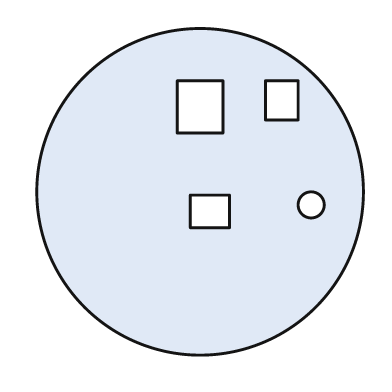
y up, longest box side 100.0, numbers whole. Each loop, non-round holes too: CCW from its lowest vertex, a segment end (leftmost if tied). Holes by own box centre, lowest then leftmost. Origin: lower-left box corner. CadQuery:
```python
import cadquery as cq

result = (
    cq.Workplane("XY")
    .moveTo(50.0, 50.0)
    .circle(50.0)
    .moveTo(47.0, 39.0)
    .lineTo(59.0, 39.0)
    .lineTo(59.0, 49.0)
    .lineTo(47.0, 49.0)
    .close()
    .moveTo(84.0, 46.0)
    .circle(4.0)
    .moveTo(43.0, 68.0)
    .lineTo(57.0, 68.0)
    .lineTo(57.0, 84.0)
    .lineTo(43.0, 84.0)
    .close()
    .moveTo(70.0, 72.0)
    .lineTo(80.0, 72.0)
    .lineTo(80.0, 84.0)
    .lineTo(70.0, 84.0)
    .close()
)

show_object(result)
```